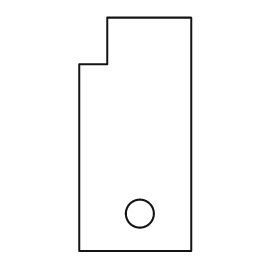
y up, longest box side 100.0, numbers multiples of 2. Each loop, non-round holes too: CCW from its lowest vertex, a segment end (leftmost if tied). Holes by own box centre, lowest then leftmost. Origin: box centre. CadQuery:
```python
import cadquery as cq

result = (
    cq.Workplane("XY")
    .moveTo(-24.0, -50.0)
    .lineTo(24.0, -50.0)
    .lineTo(24.0, 50.0)
    .lineTo(-12.0, 50.0)
    .lineTo(-12.0, 30.0)
    .lineTo(-24.0, 30.0)
    .close()
    .moveTo(2.0, -34.0)
    .circle(6.0)
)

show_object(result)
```